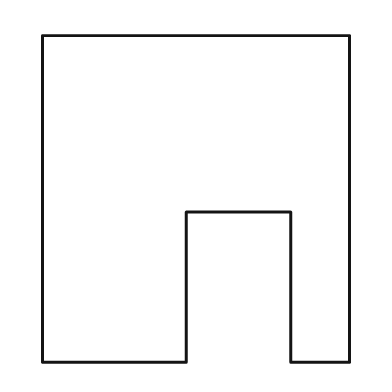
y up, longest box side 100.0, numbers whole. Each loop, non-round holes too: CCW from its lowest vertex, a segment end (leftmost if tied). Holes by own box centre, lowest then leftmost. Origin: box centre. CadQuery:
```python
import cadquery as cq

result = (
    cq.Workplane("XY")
    .moveTo(-47.0, -50.0)
    .lineTo(-3.0, -50.0)
    .lineTo(-3.0, -4.0)
    .lineTo(29.0, -4.0)
    .lineTo(29.0, -50.0)
    .lineTo(47.0, -50.0)
    .lineTo(47.0, 50.0)
    .lineTo(-47.0, 50.0)
    .close()
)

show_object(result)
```